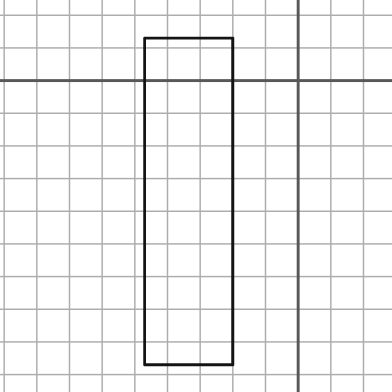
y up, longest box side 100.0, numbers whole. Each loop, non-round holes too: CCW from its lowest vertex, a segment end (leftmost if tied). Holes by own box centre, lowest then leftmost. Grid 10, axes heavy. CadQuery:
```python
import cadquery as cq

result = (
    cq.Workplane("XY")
    .moveTo(-47.0, -87.0)
    .lineTo(-20.0, -87.0)
    .lineTo(-20.0, 13.0)
    .lineTo(-47.0, 13.0)
    .close()
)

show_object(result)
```